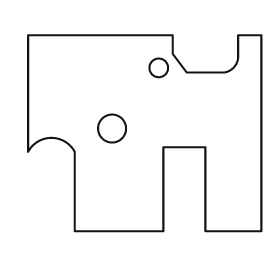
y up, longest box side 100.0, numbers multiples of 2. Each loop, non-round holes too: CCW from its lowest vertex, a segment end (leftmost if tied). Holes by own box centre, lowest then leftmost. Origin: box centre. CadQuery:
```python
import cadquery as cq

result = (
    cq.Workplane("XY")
    .moveTo(-30.0, -42.0)
    .lineTo(8.0, -42.0)
    .lineTo(8.0, -6.0)
    .lineTo(26.0, -6.0)
    .lineTo(26.0, -42.0)
    .lineTo(50.0, -42.0)
    .lineTo(50.0, 42.0)
    .lineTo(40.0, 42.0)
    .lineTo(40.0, 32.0)
    .threePointArc((38.0, 28.0), (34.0, 26.0))
    .lineTo(18.0, 26.0)
    .lineTo(12.0, 34.0)
    .lineTo(12.0, 42.0)
    .lineTo(-50.0, 42.0)
    .lineTo(-50.0, -8.0)
    .threePointArc((-40.0, -2.0), (-30.0, -8.0))
    .close()
    .moveTo(-14.0, 2.0)
    .circle(6.0)
    .moveTo(6.0, 28.0)
    .circle(4.0)
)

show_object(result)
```